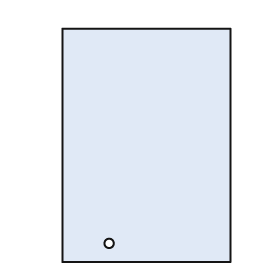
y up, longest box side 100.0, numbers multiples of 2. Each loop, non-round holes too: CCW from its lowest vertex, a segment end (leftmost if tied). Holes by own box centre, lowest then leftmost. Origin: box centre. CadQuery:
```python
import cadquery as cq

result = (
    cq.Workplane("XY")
    .moveTo(-36.0, -50.0)
    .lineTo(36.0, -50.0)
    .lineTo(36.0, 50.0)
    .lineTo(-36.0, 50.0)
    .close()
    .moveTo(-16.0, -42.0)
    .circle(2.0)
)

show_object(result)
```